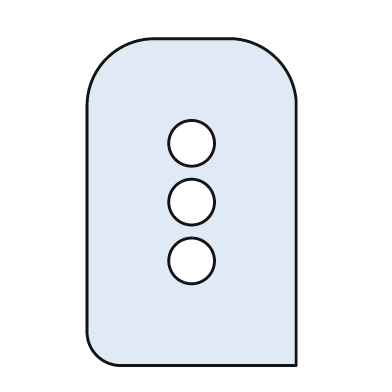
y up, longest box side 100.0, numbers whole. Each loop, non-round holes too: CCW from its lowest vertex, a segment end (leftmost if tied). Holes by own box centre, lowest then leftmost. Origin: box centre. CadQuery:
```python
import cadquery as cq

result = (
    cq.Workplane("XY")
    .moveTo(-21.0, -50.0)
    .lineTo(32.0, -50.0)
    .lineTo(32.0, 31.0)
    .threePointArc((26.0, 44.0), (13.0, 50.0))
    .lineTo(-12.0, 50.0)
    .threePointArc((-26.0, 44.0), (-32.0, 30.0))
    .lineTo(-32.0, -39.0)
    .threePointArc((-29.0, -47.0), (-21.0, -50.0))
    .close()
    .moveTo(0.0, -18.0)
    .circle(7.0)
    .moveTo(0.0, 0.0)
    .circle(7.0)
    .moveTo(0.0, 18.0)
    .circle(7.0)
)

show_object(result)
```